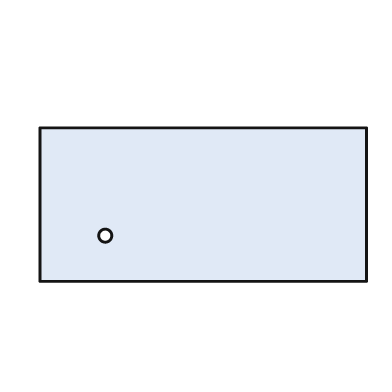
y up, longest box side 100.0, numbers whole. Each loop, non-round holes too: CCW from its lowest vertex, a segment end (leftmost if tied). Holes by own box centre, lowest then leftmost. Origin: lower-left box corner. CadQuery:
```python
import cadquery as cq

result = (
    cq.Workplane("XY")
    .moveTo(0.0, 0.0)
    .lineTo(100.0, 0.0)
    .lineTo(100.0, 47.0)
    .lineTo(0.0, 47.0)
    .close()
    .moveTo(20.0, 14.0)
    .circle(2.0)
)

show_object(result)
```